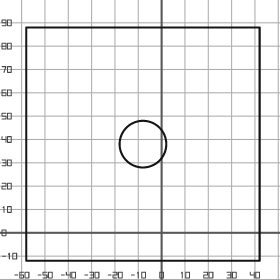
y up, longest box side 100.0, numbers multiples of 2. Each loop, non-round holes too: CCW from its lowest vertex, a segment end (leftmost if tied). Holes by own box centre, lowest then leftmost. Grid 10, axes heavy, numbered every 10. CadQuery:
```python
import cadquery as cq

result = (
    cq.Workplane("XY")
    .moveTo(-58.0, -12.0)
    .lineTo(42.0, -12.0)
    .lineTo(42.0, 88.0)
    .lineTo(-58.0, 88.0)
    .close()
    .moveTo(-8.0, 38.0)
    .circle(10.0)
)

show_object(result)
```